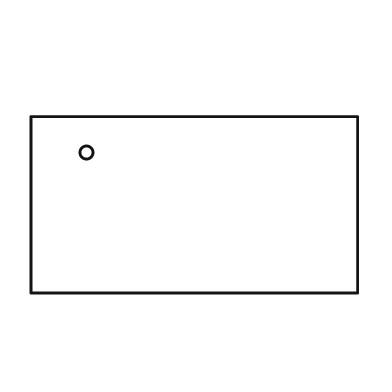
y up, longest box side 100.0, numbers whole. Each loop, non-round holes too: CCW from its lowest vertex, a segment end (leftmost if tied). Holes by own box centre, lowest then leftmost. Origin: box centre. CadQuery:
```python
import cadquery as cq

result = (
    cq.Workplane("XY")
    .moveTo(-50.0, -27.0)
    .lineTo(50.0, -27.0)
    .lineTo(50.0, 27.0)
    .lineTo(-50.0, 27.0)
    .close()
    .moveTo(-33.0, 16.0)
    .circle(2.0)
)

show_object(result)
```